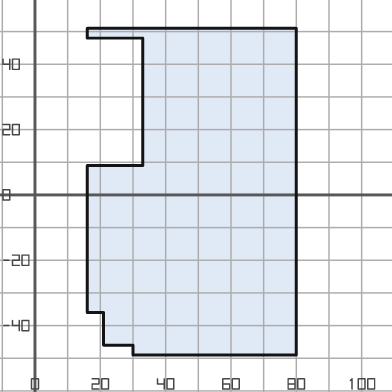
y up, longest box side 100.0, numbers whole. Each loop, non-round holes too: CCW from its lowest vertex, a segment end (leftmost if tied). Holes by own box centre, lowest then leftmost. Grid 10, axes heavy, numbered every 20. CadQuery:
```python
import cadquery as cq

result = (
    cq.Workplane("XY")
    .moveTo(30.0, -49.0)
    .lineTo(80.0, -49.0)
    .lineTo(80.0, 51.0)
    .lineTo(16.0, 51.0)
    .lineTo(16.0, 48.0)
    .lineTo(33.0, 48.0)
    .lineTo(33.0, 9.0)
    .lineTo(16.0, 9.0)
    .lineTo(16.0, -36.0)
    .lineTo(21.0, -36.0)
    .lineTo(21.0, -46.0)
    .lineTo(30.0, -46.0)
    .close()
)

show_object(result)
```